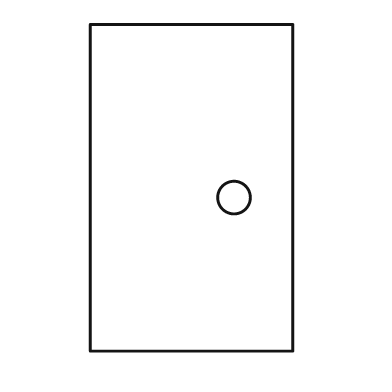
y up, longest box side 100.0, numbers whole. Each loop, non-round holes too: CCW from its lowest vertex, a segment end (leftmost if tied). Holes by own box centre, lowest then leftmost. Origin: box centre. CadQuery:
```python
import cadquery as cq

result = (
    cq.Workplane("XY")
    .moveTo(-31.0, -50.0)
    .lineTo(31.0, -50.0)
    .lineTo(31.0, 50.0)
    .lineTo(-31.0, 50.0)
    .close()
    .moveTo(13.0, -3.0)
    .circle(5.0)
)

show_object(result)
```